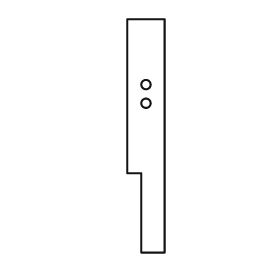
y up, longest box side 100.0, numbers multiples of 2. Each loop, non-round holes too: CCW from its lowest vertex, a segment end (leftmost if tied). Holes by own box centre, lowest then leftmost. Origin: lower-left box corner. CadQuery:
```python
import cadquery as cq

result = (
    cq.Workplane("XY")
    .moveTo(6.0, 0.0)
    .lineTo(16.0, 0.0)
    .lineTo(16.0, 100.0)
    .lineTo(0.0, 100.0)
    .lineTo(0.0, 34.0)
    .lineTo(6.0, 34.0)
    .close()
    .moveTo(8.0, 64.0)
    .circle(2.0)
    .moveTo(8.0, 72.0)
    .circle(2.0)
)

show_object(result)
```